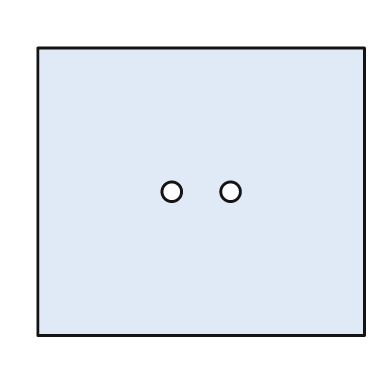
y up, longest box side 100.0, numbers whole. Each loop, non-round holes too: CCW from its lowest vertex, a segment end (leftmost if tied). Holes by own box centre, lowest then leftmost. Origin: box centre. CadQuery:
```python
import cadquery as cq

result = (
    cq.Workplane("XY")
    .moveTo(-50.0, -44.0)
    .lineTo(50.0, -44.0)
    .lineTo(50.0, 44.0)
    .lineTo(-50.0, 44.0)
    .close()
    .moveTo(-9.0, 0.0)
    .circle(3.0)
    .moveTo(9.0, 0.0)
    .circle(3.0)
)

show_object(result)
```